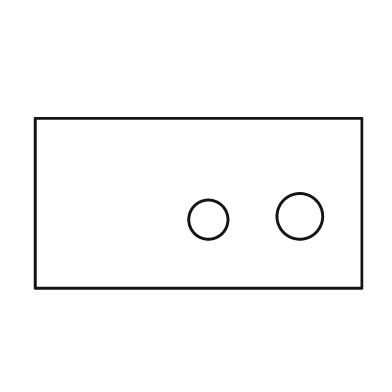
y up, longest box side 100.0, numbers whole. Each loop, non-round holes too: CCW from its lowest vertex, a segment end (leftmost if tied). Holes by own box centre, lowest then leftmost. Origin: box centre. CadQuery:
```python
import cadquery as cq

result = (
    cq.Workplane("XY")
    .moveTo(-50.0, -26.0)
    .lineTo(50.0, -26.0)
    .lineTo(50.0, 26.0)
    .lineTo(-50.0, 26.0)
    .close()
    .moveTo(3.0, -5.0)
    .circle(6.0)
    .moveTo(31.0, -4.0)
    .circle(7.0)
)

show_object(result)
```